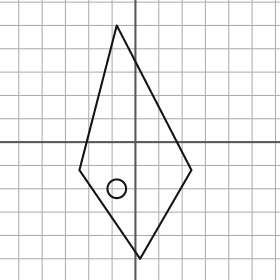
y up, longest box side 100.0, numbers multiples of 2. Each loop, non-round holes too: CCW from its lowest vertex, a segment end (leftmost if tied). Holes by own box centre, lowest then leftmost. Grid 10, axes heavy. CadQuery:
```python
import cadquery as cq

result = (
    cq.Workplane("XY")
    .moveTo(2.0, -50.0)
    .lineTo(24.0, -12.0)
    .lineTo(-8.0, 50.0)
    .lineTo(-24.0, -12.0)
    .close()
    .moveTo(-8.0, -20.0)
    .circle(4.0)
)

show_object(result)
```